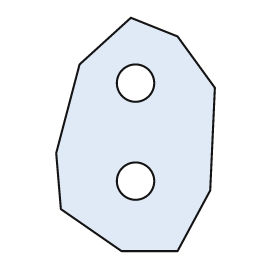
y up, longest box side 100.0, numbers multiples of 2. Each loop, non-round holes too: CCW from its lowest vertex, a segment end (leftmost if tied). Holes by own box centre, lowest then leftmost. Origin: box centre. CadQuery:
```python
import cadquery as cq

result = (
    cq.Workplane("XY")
    .moveTo(-6.0, -50.0)
    .lineTo(18.0, -50.0)
    .lineTo(32.0, -24.0)
    .lineTo(34.0, 20.0)
    .lineTo(18.0, 42.0)
    .lineTo(-2.0, 50.0)
    .lineTo(-24.0, 30.0)
    .lineTo(-34.0, -8.0)
    .lineTo(-32.0, -32.0)
    .close()
    .moveTo(0.0, -20.0)
    .circle(8.0)
    .moveTo(0.0, 22.0)
    .circle(8.0)
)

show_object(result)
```